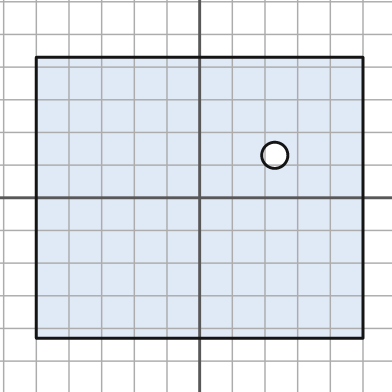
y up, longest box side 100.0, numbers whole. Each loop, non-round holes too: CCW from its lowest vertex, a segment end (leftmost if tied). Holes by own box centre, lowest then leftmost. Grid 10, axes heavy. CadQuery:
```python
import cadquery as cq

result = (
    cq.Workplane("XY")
    .moveTo(-50.0, -43.0)
    .lineTo(50.0, -43.0)
    .lineTo(50.0, 43.0)
    .lineTo(-50.0, 43.0)
    .close()
    .moveTo(23.0, 13.0)
    .circle(4.0)
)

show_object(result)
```